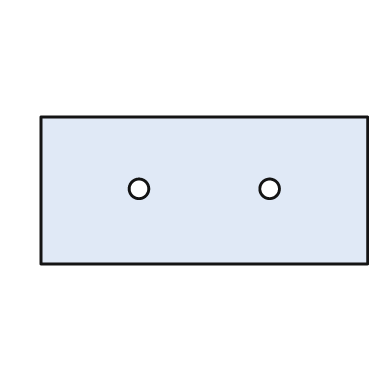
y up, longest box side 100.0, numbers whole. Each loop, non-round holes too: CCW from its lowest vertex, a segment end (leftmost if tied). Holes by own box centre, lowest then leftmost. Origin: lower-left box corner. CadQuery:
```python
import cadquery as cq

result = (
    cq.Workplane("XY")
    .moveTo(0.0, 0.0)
    .lineTo(100.0, 0.0)
    .lineTo(100.0, 45.0)
    .lineTo(0.0, 45.0)
    .close()
    .moveTo(30.0, 23.0)
    .circle(3.0)
    .moveTo(70.0, 23.0)
    .circle(3.0)
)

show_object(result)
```